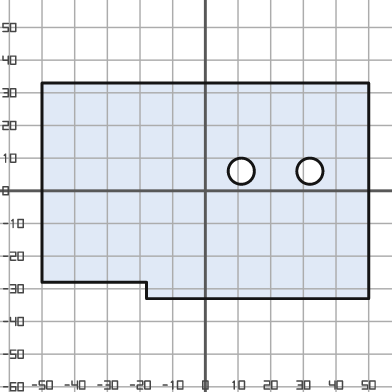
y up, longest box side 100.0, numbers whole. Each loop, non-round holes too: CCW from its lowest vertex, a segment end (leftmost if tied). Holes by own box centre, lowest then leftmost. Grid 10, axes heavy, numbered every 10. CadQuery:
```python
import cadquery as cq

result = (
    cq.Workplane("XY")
    .moveTo(-18.0, -33.0)
    .lineTo(50.0, -33.0)
    .lineTo(50.0, 33.0)
    .lineTo(-50.0, 33.0)
    .lineTo(-50.0, -28.0)
    .lineTo(-18.0, -28.0)
    .close()
    .moveTo(11.0, 6.0)
    .circle(4.0)
    .moveTo(32.0, 6.0)
    .circle(4.0)
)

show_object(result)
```